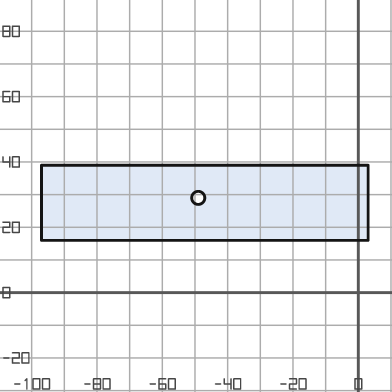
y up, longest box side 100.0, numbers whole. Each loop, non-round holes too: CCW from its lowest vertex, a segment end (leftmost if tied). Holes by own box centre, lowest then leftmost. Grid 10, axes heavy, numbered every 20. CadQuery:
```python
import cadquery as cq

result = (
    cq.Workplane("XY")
    .moveTo(-97.0, 16.0)
    .lineTo(3.0, 16.0)
    .lineTo(3.0, 39.0)
    .lineTo(-97.0, 39.0)
    .close()
    .moveTo(-49.0, 29.0)
    .circle(2.0)
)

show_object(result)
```